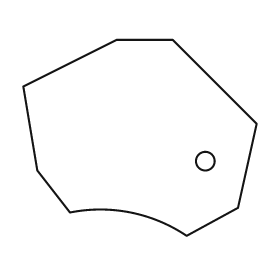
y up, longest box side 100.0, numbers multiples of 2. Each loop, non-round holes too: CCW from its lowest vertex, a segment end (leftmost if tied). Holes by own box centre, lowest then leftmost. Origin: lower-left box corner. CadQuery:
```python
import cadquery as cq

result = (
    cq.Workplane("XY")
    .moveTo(70.0, 0.0)
    .lineTo(92.0, 12.0)
    .lineTo(100.0, 48.0)
    .lineTo(64.0, 84.0)
    .lineTo(40.0, 84.0)
    .lineTo(0.0, 64.0)
    .lineTo(6.0, 28.0)
    .lineTo(20.0, 10.0)
    .threePointArc((46.0, 10.0), (70.0, 0.0))
    .close()
    .moveTo(78.0, 32.0)
    .circle(4.0)
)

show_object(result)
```